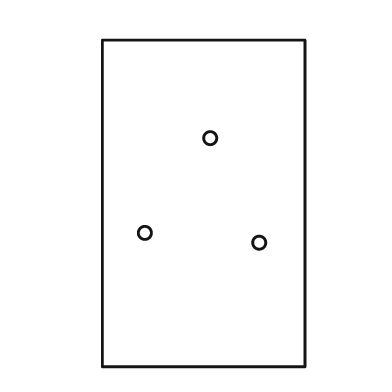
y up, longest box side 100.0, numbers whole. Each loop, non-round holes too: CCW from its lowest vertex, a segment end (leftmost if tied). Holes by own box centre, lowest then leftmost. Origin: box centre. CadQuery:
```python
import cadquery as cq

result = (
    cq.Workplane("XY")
    .moveTo(-31.0, -50.0)
    .lineTo(31.0, -50.0)
    .lineTo(31.0, 50.0)
    .lineTo(-31.0, 50.0)
    .close()
    .moveTo(17.0, -12.0)
    .circle(2.0)
    .moveTo(-18.0, -9.0)
    .circle(2.0)
    .moveTo(2.0, 20.0)
    .circle(2.0)
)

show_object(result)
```